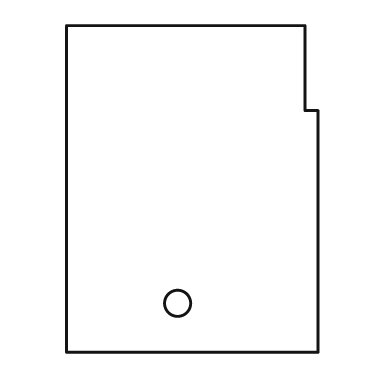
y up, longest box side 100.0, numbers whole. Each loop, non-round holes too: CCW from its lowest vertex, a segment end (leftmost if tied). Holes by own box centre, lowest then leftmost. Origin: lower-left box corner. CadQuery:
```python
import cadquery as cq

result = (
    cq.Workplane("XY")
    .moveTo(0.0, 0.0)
    .lineTo(77.0, 0.0)
    .lineTo(77.0, 74.0)
    .lineTo(73.0, 74.0)
    .lineTo(73.0, 100.0)
    .lineTo(0.0, 100.0)
    .close()
    .moveTo(34.0, 15.0)
    .circle(4.0)
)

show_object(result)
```